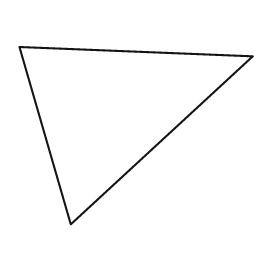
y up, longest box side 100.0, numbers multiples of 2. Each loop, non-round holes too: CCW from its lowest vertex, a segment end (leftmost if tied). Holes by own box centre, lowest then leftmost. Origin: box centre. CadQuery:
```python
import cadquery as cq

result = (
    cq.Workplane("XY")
    .moveTo(-28.0, -38.0)
    .lineTo(50.0, 34.0)
    .lineTo(-50.0, 38.0)
    .close()
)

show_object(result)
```